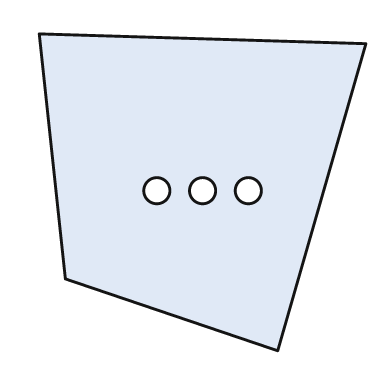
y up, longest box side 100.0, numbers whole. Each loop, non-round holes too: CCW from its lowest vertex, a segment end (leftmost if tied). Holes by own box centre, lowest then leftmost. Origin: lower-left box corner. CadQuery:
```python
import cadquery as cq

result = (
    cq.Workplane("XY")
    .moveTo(73.0, 0.0)
    .lineTo(100.0, 94.0)
    .lineTo(0.0, 97.0)
    .lineTo(8.0, 22.0)
    .close()
    .moveTo(36.0, 49.0)
    .circle(4.0)
    .moveTo(50.0, 49.0)
    .circle(4.0)
    .moveTo(64.0, 49.0)
    .circle(4.0)
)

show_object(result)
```